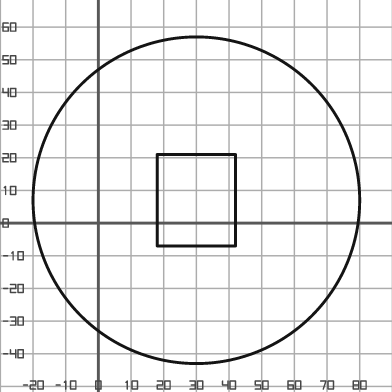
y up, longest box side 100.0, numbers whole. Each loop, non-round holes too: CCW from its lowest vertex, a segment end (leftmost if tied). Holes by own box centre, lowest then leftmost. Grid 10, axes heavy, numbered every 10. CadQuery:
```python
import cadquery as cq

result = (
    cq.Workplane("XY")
    .moveTo(30.0, 7.0)
    .circle(50.0)
    .moveTo(18.0, -7.0)
    .lineTo(42.0, -7.0)
    .lineTo(42.0, 21.0)
    .lineTo(18.0, 21.0)
    .close()
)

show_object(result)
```